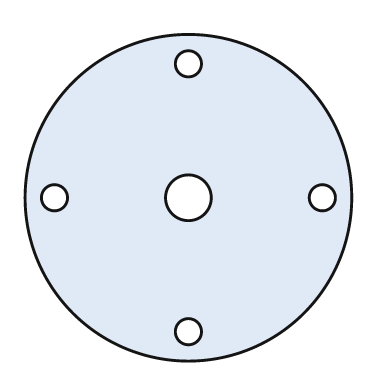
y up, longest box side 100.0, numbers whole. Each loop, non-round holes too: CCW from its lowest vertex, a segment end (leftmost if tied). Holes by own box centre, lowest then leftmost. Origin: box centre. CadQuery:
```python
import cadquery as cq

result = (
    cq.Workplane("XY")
    .moveTo(0.0, 0.0)
    .circle(50.0)
    .moveTo(0.0, -41.0)
    .circle(4.0)
    .moveTo(-41.0, 0.0)
    .circle(4.0)
    .moveTo(0.0, 0.0)
    .circle(7.0)
    .moveTo(41.0, 0.0)
    .circle(4.0)
    .moveTo(0.0, 41.0)
    .circle(4.0)
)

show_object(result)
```